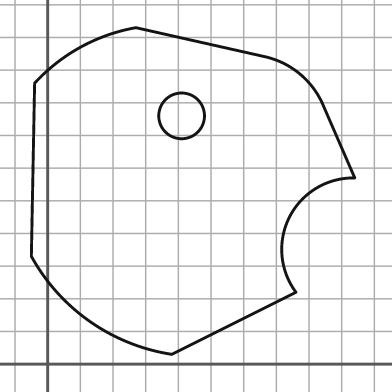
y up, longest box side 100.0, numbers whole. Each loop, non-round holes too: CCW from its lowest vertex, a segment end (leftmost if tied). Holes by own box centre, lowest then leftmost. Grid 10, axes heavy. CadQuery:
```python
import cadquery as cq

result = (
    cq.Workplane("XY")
    .moveTo(38.0, 3.0)
    .lineTo(76.0, 22.0)
    .threePointArc((74.0, 45.0), (94.0, 57.0))
    .lineTo(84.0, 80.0)
    .threePointArc((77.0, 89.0), (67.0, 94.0))
    .lineTo(27.0, 103.0)
    .threePointArc((10.0, 97.0), (-4.0, 86.0))
    .lineTo(-5.0, 33.0)
    .threePointArc((13.0, 13.0), (38.0, 3.0))
    .close()
    .moveTo(41.0, 76.0)
    .circle(7.0)
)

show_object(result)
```